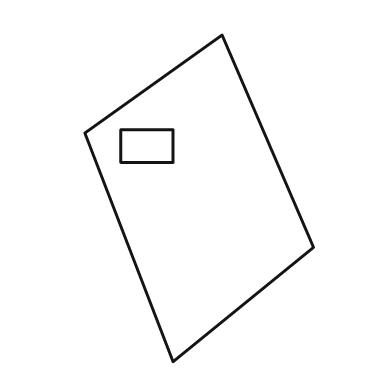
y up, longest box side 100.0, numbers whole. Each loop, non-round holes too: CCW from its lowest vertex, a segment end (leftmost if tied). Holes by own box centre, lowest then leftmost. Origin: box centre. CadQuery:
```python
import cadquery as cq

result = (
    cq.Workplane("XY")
    .moveTo(-8.0, -50.0)
    .lineTo(35.0, -15.0)
    .lineTo(7.0, 50.0)
    .lineTo(-35.0, 20.0)
    .close()
    .moveTo(-24.0, 11.0)
    .lineTo(-8.0, 11.0)
    .lineTo(-8.0, 21.0)
    .lineTo(-24.0, 21.0)
    .close()
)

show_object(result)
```